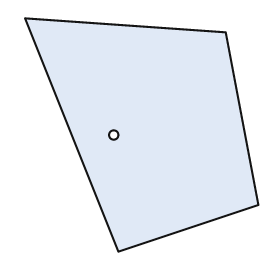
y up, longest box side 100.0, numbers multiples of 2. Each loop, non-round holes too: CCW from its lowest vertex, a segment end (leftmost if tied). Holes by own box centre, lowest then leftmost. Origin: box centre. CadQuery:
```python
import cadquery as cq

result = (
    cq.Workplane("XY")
    .moveTo(-10.0, -50.0)
    .lineTo(50.0, -30.0)
    .lineTo(36.0, 44.0)
    .lineTo(-50.0, 50.0)
    .close()
    .moveTo(-12.0, 0.0)
    .circle(2.0)
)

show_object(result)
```